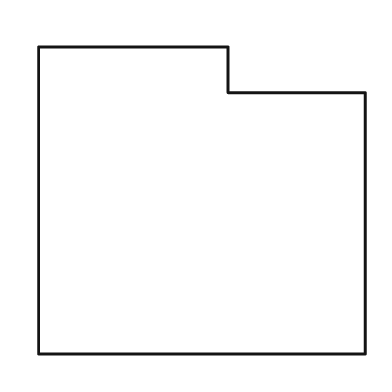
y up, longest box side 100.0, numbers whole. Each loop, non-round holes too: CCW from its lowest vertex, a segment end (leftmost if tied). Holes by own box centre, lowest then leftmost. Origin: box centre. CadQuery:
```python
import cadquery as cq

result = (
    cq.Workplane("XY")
    .moveTo(-50.0, -47.0)
    .lineTo(50.0, -47.0)
    .lineTo(50.0, 33.0)
    .lineTo(8.0, 33.0)
    .lineTo(8.0, 47.0)
    .lineTo(-50.0, 47.0)
    .close()
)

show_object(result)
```